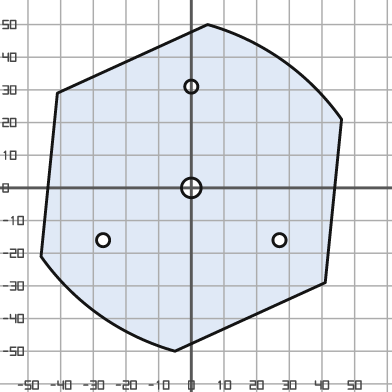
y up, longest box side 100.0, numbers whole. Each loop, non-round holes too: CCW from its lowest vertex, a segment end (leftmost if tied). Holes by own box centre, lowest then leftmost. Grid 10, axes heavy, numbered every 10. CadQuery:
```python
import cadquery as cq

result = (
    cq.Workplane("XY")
    .moveTo(-5.0, -50.0)
    .lineTo(41.0, -29.0)
    .lineTo(46.0, 21.0)
    .threePointArc((28.0, 39.0), (5.0, 50.0))
    .lineTo(-41.0, 29.0)
    .lineTo(-46.0, -21.0)
    .threePointArc((-28.0, -39.0), (-5.0, -50.0))
    .close()
    .moveTo(-27.0, -16.0)
    .circle(2.0)
    .moveTo(27.0, -16.0)
    .circle(2.0)
    .moveTo(0.0, 0.0)
    .circle(3.0)
    .moveTo(0.0, 31.0)
    .circle(2.0)
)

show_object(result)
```